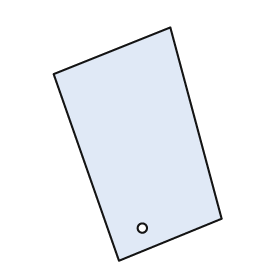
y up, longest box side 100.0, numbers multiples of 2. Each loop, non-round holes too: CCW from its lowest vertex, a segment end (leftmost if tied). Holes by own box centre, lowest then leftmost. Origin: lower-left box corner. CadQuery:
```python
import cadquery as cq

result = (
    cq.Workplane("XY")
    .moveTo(28.0, 0.0)
    .lineTo(72.0, 18.0)
    .lineTo(50.0, 100.0)
    .lineTo(0.0, 80.0)
    .close()
    .moveTo(38.0, 14.0)
    .circle(2.0)
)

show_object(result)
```